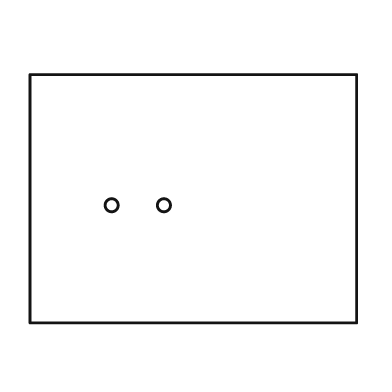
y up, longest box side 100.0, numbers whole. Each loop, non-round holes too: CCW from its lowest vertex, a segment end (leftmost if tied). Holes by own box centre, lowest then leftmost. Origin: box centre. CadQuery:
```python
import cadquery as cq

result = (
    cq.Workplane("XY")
    .moveTo(-50.0, -38.0)
    .lineTo(50.0, -38.0)
    .lineTo(50.0, 38.0)
    .lineTo(-50.0, 38.0)
    .close()
    .moveTo(-25.0, -2.0)
    .circle(2.0)
    .moveTo(-9.0, -2.0)
    .circle(2.0)
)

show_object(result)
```